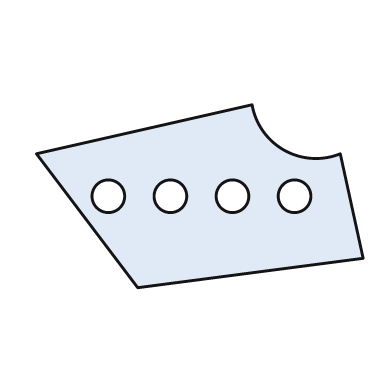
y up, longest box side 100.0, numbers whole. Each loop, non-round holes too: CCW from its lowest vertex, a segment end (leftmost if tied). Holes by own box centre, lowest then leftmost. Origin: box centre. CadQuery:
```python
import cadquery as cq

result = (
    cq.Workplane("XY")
    .moveTo(-19.0, -28.0)
    .lineTo(50.0, -19.0)
    .lineTo(43.0, 13.0)
    .threePointArc((26.0, 14.0), (16.0, 28.0))
    .lineTo(-50.0, 13.0)
    .close()
    .moveTo(-28.0, 0.0)
    .circle(5.0)
    .moveTo(-9.0, 0.0)
    .circle(5.0)
    .moveTo(10.0, 0.0)
    .circle(5.0)
    .moveTo(29.0, 0.0)
    .circle(5.0)
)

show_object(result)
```